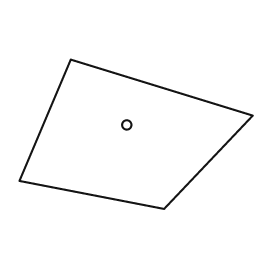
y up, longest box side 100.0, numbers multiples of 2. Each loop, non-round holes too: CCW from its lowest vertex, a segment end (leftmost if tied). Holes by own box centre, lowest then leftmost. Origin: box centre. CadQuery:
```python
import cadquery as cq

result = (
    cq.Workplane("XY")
    .moveTo(12.0, -32.0)
    .lineTo(50.0, 8.0)
    .lineTo(-28.0, 32.0)
    .lineTo(-50.0, -20.0)
    .close()
    .moveTo(-4.0, 4.0)
    .circle(2.0)
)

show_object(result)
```